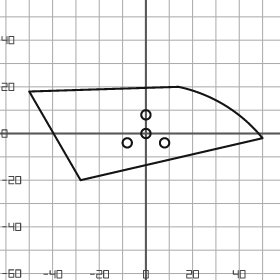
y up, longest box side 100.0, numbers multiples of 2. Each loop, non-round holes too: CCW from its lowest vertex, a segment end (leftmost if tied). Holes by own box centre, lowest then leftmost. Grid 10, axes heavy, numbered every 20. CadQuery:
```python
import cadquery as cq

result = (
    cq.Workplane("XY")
    .moveTo(-28.0, -20.0)
    .lineTo(50.0, -2.0)
    .threePointArc((34.0, 12.0), (14.0, 20.0))
    .lineTo(-50.0, 18.0)
    .close()
    .moveTo(-8.0, -4.0)
    .circle(2.0)
    .moveTo(8.0, -4.0)
    .circle(2.0)
    .moveTo(0.0, 0.0)
    .circle(2.0)
    .moveTo(0.0, 8.0)
    .circle(2.0)
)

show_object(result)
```